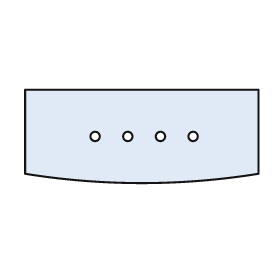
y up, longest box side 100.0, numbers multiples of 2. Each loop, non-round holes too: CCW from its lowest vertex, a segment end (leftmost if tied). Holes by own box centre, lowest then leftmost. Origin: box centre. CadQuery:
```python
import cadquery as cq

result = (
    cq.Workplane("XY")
    .moveTo(-50.0, -16.0)
    .threePointArc((0.0, -20.0), (50.0, -16.0))
    .lineTo(50.0, 20.0)
    .lineTo(-50.0, 20.0)
    .close()
    .moveTo(-20.0, 0.0)
    .circle(2.0)
    .moveTo(-6.0, 0.0)
    .circle(2.0)
    .moveTo(8.0, 0.0)
    .circle(2.0)
    .moveTo(22.0, 0.0)
    .circle(2.0)
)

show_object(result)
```